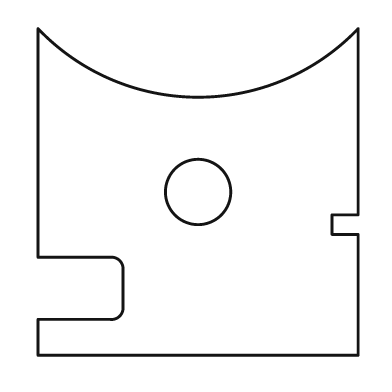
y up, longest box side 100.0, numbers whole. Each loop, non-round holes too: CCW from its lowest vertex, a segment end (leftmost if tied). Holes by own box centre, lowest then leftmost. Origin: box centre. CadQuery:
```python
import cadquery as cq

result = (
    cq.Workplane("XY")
    .moveTo(-49.0, -50.0)
    .lineTo(49.0, -50.0)
    .lineTo(49.0, -13.0)
    .lineTo(41.0, -13.0)
    .lineTo(41.0, -7.0)
    .lineTo(49.0, -7.0)
    .lineTo(49.0, 50.0)
    .threePointArc((0.0, 29.0), (-49.0, 50.0))
    .lineTo(-49.0, -20.0)
    .lineTo(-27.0, -20.0)
    .threePointArc((-24.0, -21.0), (-23.0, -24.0))
    .lineTo(-23.0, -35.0)
    .threePointArc((-24.0, -38.0), (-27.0, -39.0))
    .lineTo(-49.0, -39.0)
    .close()
    .moveTo(0.0, 0.0)
    .circle(10.0)
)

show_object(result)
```